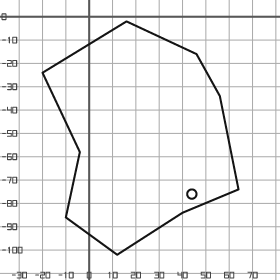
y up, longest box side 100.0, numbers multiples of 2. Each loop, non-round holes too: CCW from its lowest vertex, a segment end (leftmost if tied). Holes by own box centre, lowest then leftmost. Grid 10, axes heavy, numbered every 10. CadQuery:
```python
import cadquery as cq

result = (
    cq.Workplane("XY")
    .moveTo(12.0, -102.0)
    .lineTo(40.0, -84.0)
    .lineTo(64.0, -74.0)
    .lineTo(56.0, -34.0)
    .lineTo(46.0, -16.0)
    .lineTo(16.0, -2.0)
    .lineTo(-20.0, -24.0)
    .lineTo(-4.0, -58.0)
    .lineTo(-10.0, -86.0)
    .close()
    .moveTo(44.0, -76.0)
    .circle(2.0)
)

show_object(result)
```